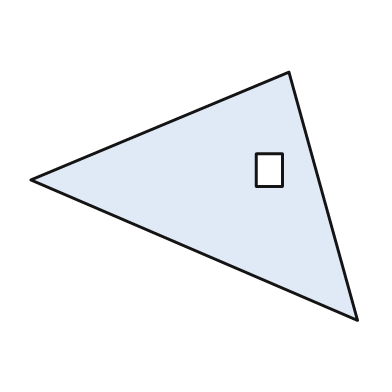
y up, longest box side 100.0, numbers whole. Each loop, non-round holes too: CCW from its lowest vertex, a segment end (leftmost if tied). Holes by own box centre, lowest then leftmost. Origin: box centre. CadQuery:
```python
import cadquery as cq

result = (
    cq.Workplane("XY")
    .moveTo(50.0, -38.0)
    .lineTo(29.0, 38.0)
    .lineTo(-50.0, 5.0)
    .close()
    .moveTo(19.0, 3.0)
    .lineTo(27.0, 3.0)
    .lineTo(27.0, 13.0)
    .lineTo(19.0, 13.0)
    .close()
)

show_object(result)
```